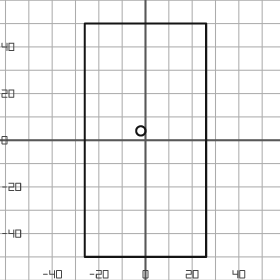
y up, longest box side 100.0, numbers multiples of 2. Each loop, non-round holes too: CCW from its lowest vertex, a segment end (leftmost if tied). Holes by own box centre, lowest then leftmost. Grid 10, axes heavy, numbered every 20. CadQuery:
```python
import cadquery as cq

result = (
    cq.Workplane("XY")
    .moveTo(-26.0, -50.0)
    .lineTo(26.0, -50.0)
    .lineTo(26.0, 50.0)
    .lineTo(-26.0, 50.0)
    .close()
    .moveTo(-2.0, 4.0)
    .circle(2.0)
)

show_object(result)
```